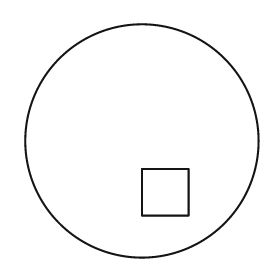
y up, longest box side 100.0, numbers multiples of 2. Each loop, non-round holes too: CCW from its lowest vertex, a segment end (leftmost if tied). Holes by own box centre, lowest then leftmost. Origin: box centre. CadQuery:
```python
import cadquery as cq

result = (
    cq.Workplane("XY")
    .moveTo(0.0, 0.0)
    .circle(50.0)
    .moveTo(0.0, -32.0)
    .lineTo(20.0, -32.0)
    .lineTo(20.0, -12.0)
    .lineTo(0.0, -12.0)
    .close()
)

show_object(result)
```